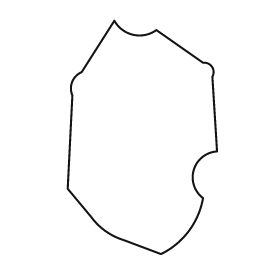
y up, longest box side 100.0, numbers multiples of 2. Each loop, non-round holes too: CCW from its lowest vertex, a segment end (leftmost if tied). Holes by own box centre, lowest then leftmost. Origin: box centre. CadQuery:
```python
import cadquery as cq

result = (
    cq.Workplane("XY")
    .moveTo(8.0, -50.0)
    .threePointArc((20.0, -40.0), (26.0, -26.0))
    .threePointArc((22.0, -14.0), (32.0, -6.0))
    .lineTo(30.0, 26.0)
    .threePointArc((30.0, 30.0), (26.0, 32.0))
    .lineTo(6.0, 46.0)
    .threePointArc((-4.0, 44.0), (-12.0, 50.0))
    .lineTo(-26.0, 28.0)
    .threePointArc((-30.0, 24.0), (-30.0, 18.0))
    .lineTo(-32.0, -22.0)
    .lineTo(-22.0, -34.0)
    .threePointArc((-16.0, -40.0), (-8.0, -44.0))
    .close()
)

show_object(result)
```